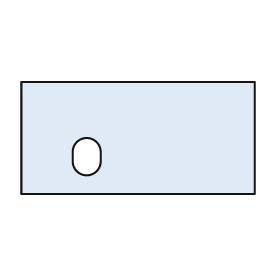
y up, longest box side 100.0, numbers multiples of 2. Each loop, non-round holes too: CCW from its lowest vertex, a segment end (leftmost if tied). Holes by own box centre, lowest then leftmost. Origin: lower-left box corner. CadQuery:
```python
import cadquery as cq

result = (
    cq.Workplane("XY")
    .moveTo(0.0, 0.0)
    .lineTo(100.0, 0.0)
    .lineTo(100.0, 48.0)
    .lineTo(0.0, 48.0)
    .close()
    .moveTo(22.0, 14.0)
    .threePointArc((28.0, 8.0), (34.0, 14.0))
    .lineTo(34.0, 18.0)
    .threePointArc((28.0, 24.0), (22.0, 18.0))
    .close()
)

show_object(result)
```